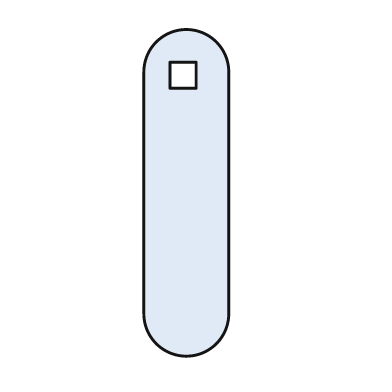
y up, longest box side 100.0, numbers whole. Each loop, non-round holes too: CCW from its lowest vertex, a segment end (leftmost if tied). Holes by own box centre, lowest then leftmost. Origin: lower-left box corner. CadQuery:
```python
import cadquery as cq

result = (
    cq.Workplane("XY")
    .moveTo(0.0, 13.0)
    .threePointArc((13.0, 0.0), (26.0, 13.0))
    .lineTo(26.0, 87.0)
    .threePointArc((13.0, 100.0), (0.0, 87.0))
    .close()
    .moveTo(8.0, 82.0)
    .lineTo(16.0, 82.0)
    .lineTo(16.0, 90.0)
    .lineTo(8.0, 90.0)
    .close()
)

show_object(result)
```